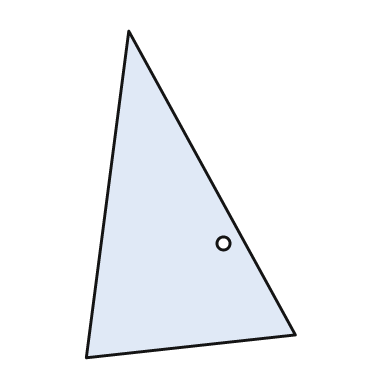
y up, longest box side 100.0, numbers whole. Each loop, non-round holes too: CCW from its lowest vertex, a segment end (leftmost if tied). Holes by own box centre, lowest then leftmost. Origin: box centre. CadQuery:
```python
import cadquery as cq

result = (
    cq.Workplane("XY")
    .moveTo(-32.0, -50.0)
    .lineTo(32.0, -43.0)
    .lineTo(-19.0, 50.0)
    .close()
    .moveTo(10.0, -15.0)
    .circle(2.0)
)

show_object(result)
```